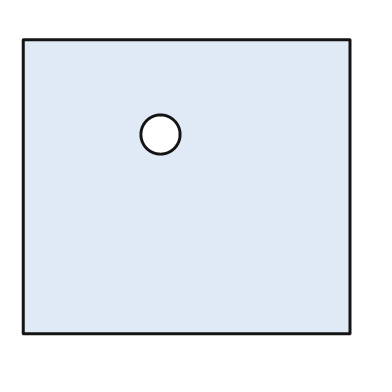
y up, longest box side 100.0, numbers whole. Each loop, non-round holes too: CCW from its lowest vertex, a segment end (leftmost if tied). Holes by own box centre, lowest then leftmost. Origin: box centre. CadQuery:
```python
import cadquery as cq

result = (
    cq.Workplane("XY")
    .moveTo(-50.0, -45.0)
    .lineTo(50.0, -45.0)
    .lineTo(50.0, 45.0)
    .lineTo(-50.0, 45.0)
    .close()
    .moveTo(-8.0, 16.0)
    .circle(6.0)
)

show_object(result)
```